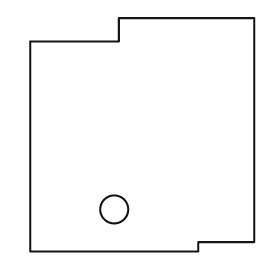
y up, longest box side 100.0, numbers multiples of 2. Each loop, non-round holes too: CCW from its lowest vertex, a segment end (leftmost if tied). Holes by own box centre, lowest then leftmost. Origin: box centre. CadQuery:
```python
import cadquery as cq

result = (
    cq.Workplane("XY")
    .moveTo(-48.0, -50.0)
    .lineTo(24.0, -50.0)
    .lineTo(24.0, -46.0)
    .lineTo(48.0, -46.0)
    .lineTo(48.0, 50.0)
    .lineTo(-10.0, 50.0)
    .lineTo(-10.0, 40.0)
    .lineTo(-48.0, 40.0)
    .close()
    .moveTo(-12.0, -32.0)
    .circle(6.0)
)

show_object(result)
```